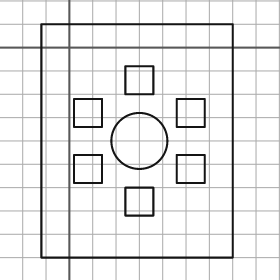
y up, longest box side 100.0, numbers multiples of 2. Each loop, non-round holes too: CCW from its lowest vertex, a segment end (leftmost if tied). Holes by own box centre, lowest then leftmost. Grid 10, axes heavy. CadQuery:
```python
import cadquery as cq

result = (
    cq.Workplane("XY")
    .moveTo(-12.0, -90.0)
    .lineTo(70.0, -90.0)
    .lineTo(70.0, 10.0)
    .lineTo(-12.0, 10.0)
    .close()
    .moveTo(24.0, -72.0)
    .lineTo(36.0, -72.0)
    .lineTo(36.0, -60.0)
    .lineTo(24.0, -60.0)
    .close()
    .moveTo(2.0, -58.0)
    .lineTo(14.0, -58.0)
    .lineTo(14.0, -46.0)
    .lineTo(2.0, -46.0)
    .close()
    .moveTo(46.0, -58.0)
    .lineTo(58.0, -58.0)
    .lineTo(58.0, -46.0)
    .lineTo(46.0, -46.0)
    .close()
    .moveTo(30.0, -40.0)
    .circle(12.0)
    .moveTo(2.0, -34.0)
    .lineTo(14.0, -34.0)
    .lineTo(14.0, -22.0)
    .lineTo(2.0, -22.0)
    .close()
    .moveTo(46.0, -34.0)
    .lineTo(58.0, -34.0)
    .lineTo(58.0, -22.0)
    .lineTo(46.0, -22.0)
    .close()
    .moveTo(24.0, -20.0)
    .lineTo(36.0, -20.0)
    .lineTo(36.0, -8.0)
    .lineTo(24.0, -8.0)
    .close()
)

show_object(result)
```